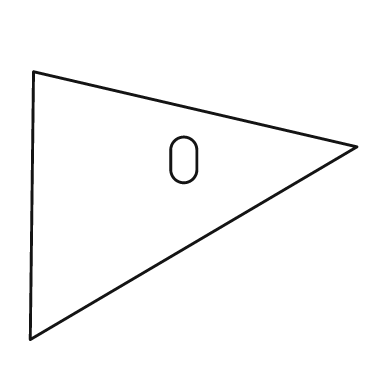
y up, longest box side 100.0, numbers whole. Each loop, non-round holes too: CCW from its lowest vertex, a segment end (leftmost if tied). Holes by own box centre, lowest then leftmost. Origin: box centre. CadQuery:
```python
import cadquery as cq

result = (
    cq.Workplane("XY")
    .moveTo(-50.0, -41.0)
    .lineTo(50.0, 18.0)
    .lineTo(-49.0, 41.0)
    .close()
    .moveTo(-7.0, 11.0)
    .threePointArc((-3.0, 7.0), (1.0, 11.0))
    .lineTo(1.0, 17.0)
    .threePointArc((-3.0, 21.0), (-7.0, 17.0))
    .close()
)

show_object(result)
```